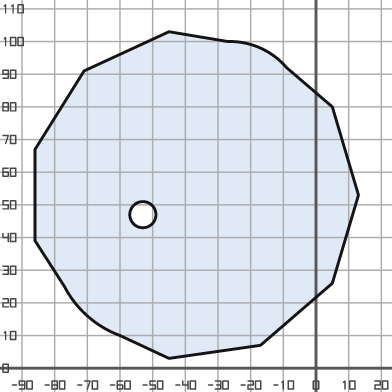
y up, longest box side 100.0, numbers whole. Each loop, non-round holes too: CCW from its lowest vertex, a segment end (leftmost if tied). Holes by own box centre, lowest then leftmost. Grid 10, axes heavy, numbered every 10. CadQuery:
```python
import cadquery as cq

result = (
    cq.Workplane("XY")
    .moveTo(-45.0, 3.0)
    .lineTo(-17.0, 7.0)
    .lineTo(5.0, 26.0)
    .lineTo(13.0, 53.0)
    .lineTo(5.0, 80.0)
    .lineTo(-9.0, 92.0)
    .threePointArc((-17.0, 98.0), (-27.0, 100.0))
    .lineTo(-45.0, 103.0)
    .lineTo(-71.0, 91.0)
    .lineTo(-86.0, 67.0)
    .lineTo(-86.0, 39.0)
    .lineTo(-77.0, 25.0)
    .threePointArc((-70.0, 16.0), (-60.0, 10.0))
    .close()
    .moveTo(-53.0, 47.0)
    .circle(4.0)
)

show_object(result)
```